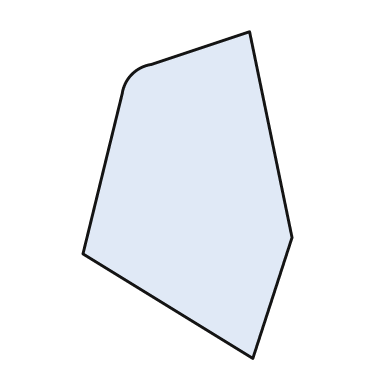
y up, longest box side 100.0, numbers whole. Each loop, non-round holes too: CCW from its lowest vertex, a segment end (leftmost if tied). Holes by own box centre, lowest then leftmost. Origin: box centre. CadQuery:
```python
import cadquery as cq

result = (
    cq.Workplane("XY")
    .moveTo(20.0, -50.0)
    .lineTo(32.0, -13.0)
    .lineTo(19.0, 50.0)
    .lineTo(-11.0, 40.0)
    .threePointArc((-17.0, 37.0), (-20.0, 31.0))
    .lineTo(-32.0, -18.0)
    .close()
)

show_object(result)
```